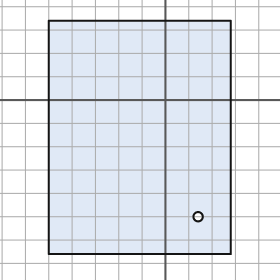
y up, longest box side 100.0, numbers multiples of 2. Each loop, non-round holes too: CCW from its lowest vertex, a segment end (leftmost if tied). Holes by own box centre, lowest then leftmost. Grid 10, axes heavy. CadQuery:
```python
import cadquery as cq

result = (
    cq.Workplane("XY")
    .moveTo(-50.0, -66.0)
    .lineTo(28.0, -66.0)
    .lineTo(28.0, 34.0)
    .lineTo(-50.0, 34.0)
    .close()
    .moveTo(14.0, -50.0)
    .circle(2.0)
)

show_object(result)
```